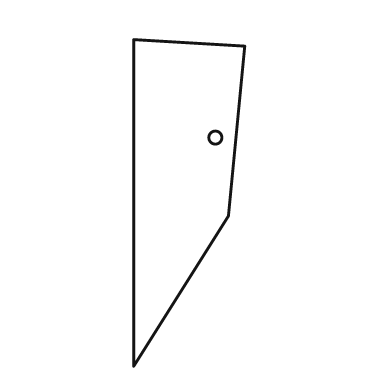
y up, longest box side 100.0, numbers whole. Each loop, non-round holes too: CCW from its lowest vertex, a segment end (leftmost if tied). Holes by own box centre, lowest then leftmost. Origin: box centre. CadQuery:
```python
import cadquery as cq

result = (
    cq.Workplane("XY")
    .moveTo(-17.0, -50.0)
    .lineTo(12.0, -4.0)
    .lineTo(17.0, 48.0)
    .lineTo(-17.0, 50.0)
    .close()
    .moveTo(8.0, 20.0)
    .circle(2.0)
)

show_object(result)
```